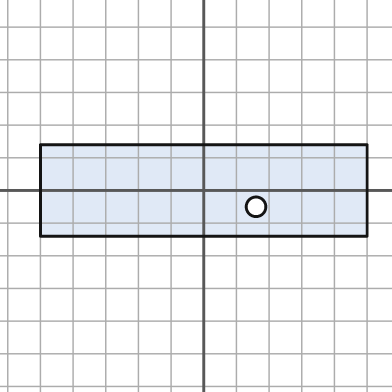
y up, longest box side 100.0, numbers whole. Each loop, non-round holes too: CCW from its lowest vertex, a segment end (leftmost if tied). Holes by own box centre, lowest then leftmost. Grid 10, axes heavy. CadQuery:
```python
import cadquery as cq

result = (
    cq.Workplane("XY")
    .moveTo(-50.0, -14.0)
    .lineTo(50.0, -14.0)
    .lineTo(50.0, 14.0)
    .lineTo(-50.0, 14.0)
    .close()
    .moveTo(16.0, -5.0)
    .circle(3.0)
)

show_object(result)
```